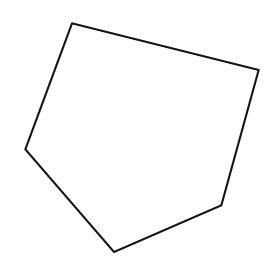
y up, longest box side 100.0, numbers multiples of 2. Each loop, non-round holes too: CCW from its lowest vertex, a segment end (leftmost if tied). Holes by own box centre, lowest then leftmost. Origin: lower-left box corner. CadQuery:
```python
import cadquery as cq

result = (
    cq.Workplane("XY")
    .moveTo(38.0, 0.0)
    .lineTo(84.0, 20.0)
    .lineTo(100.0, 78.0)
    .lineTo(20.0, 98.0)
    .lineTo(0.0, 44.0)
    .close()
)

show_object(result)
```